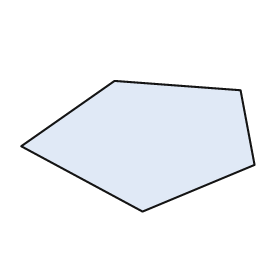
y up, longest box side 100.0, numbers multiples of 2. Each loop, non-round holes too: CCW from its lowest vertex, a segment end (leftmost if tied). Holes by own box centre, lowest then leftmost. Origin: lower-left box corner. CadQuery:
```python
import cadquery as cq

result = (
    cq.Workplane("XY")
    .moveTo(52.0, 0.0)
    .lineTo(100.0, 20.0)
    .lineTo(94.0, 52.0)
    .lineTo(40.0, 56.0)
    .lineTo(0.0, 28.0)
    .close()
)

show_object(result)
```